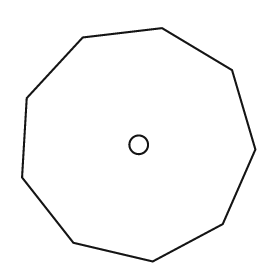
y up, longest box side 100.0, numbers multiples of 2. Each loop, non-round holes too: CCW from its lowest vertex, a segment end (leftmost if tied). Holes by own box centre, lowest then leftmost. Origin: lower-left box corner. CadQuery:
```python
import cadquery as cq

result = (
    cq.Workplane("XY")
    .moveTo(56.0, 0.0)
    .lineTo(86.0, 16.0)
    .lineTo(100.0, 48.0)
    .lineTo(90.0, 82.0)
    .lineTo(60.0, 100.0)
    .lineTo(26.0, 96.0)
    .lineTo(2.0, 70.0)
    .lineTo(0.0, 36.0)
    .lineTo(22.0, 8.0)
    .close()
    .moveTo(50.0, 50.0)
    .circle(4.0)
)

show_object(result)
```